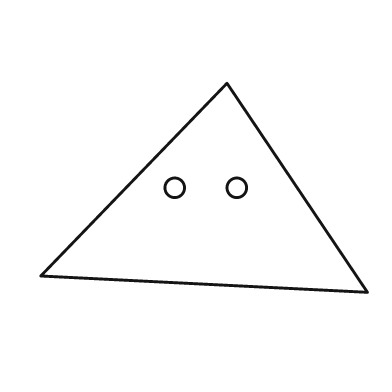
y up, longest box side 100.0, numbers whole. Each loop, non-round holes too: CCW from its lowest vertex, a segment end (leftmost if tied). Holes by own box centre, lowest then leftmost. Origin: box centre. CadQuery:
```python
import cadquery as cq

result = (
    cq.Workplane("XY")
    .moveTo(50.0, -32.0)
    .lineTo(7.0, 32.0)
    .lineTo(-50.0, -27.0)
    .close()
    .moveTo(-9.0, 0.0)
    .circle(3.0)
    .moveTo(10.0, 0.0)
    .circle(3.0)
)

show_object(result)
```